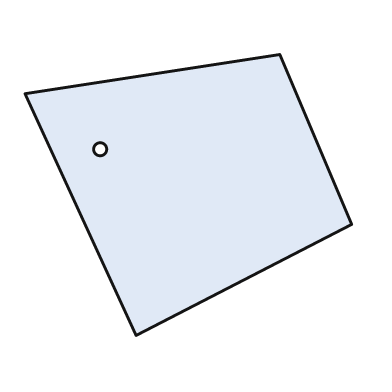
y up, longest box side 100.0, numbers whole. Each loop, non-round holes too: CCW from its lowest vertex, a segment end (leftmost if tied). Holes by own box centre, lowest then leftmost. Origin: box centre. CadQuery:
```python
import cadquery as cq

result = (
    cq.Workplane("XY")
    .moveTo(-16.0, -43.0)
    .lineTo(50.0, -9.0)
    .lineTo(28.0, 43.0)
    .lineTo(-50.0, 31.0)
    .close()
    .moveTo(-27.0, 14.0)
    .circle(2.0)
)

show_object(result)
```